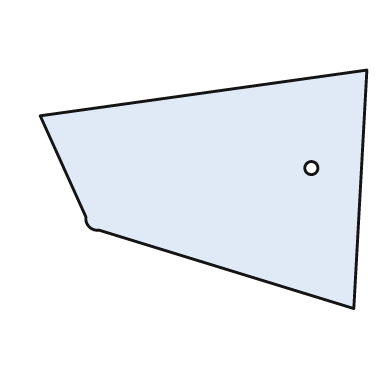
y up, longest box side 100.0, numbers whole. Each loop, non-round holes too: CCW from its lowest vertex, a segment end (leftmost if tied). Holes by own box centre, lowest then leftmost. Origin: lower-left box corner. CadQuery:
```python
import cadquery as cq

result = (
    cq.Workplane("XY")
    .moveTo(96.0, 0.0)
    .lineTo(100.0, 73.0)
    .lineTo(0.0, 59.0)
    .lineTo(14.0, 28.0)
    .threePointArc((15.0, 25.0), (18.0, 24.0))
    .close()
    .moveTo(83.0, 43.0)
    .circle(2.0)
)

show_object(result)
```